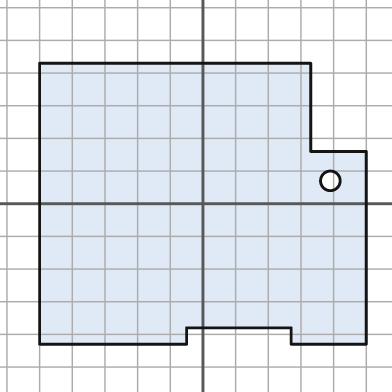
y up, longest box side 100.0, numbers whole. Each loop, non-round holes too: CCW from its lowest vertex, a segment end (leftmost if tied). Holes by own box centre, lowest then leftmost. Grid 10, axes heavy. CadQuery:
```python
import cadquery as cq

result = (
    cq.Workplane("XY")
    .moveTo(-50.0, -43.0)
    .lineTo(-5.0, -43.0)
    .lineTo(-5.0, -38.0)
    .lineTo(27.0, -38.0)
    .lineTo(27.0, -43.0)
    .lineTo(50.0, -43.0)
    .lineTo(50.0, 16.0)
    .lineTo(33.0, 16.0)
    .lineTo(33.0, 43.0)
    .lineTo(-50.0, 43.0)
    .close()
    .moveTo(39.0, 7.0)
    .circle(3.0)
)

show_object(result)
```